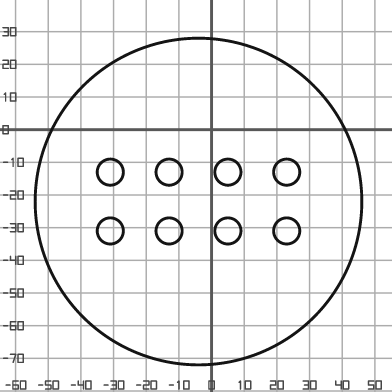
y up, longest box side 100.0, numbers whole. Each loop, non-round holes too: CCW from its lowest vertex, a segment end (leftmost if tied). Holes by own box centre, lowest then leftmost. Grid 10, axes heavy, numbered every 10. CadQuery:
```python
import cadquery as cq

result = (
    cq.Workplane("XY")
    .moveTo(-4.0, -22.0)
    .circle(50.0)
    .moveTo(-31.0, -31.0)
    .circle(4.0)
    .moveTo(-13.0, -31.0)
    .circle(4.0)
    .moveTo(5.0, -31.0)
    .circle(4.0)
    .moveTo(23.0, -31.0)
    .circle(4.0)
    .moveTo(-31.0, -13.0)
    .circle(4.0)
    .moveTo(-13.0, -13.0)
    .circle(4.0)
    .moveTo(5.0, -13.0)
    .circle(4.0)
    .moveTo(23.0, -13.0)
    .circle(4.0)
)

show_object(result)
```